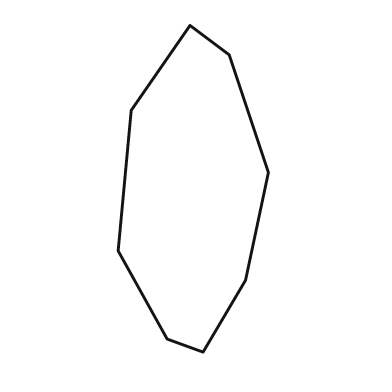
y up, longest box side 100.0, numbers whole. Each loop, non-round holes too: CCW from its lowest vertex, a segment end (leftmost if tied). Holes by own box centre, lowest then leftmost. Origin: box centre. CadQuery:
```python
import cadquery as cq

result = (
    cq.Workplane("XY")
    .moveTo(3.0, -50.0)
    .lineTo(16.0, -28.0)
    .lineTo(23.0, 5.0)
    .lineTo(11.0, 41.0)
    .lineTo(-1.0, 50.0)
    .lineTo(-19.0, 24.0)
    .lineTo(-23.0, -19.0)
    .lineTo(-8.0, -46.0)
    .close()
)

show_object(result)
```